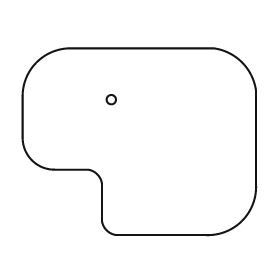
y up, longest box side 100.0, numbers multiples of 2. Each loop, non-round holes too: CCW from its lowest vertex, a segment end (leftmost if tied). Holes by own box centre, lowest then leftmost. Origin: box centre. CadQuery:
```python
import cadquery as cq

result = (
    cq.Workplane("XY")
    .moveTo(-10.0, -40.0)
    .lineTo(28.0, -40.0)
    .threePointArc((44.0, -34.0), (50.0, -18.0))
    .lineTo(50.0, 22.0)
    .threePointArc((44.0, 34.0), (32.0, 40.0))
    .lineTo(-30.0, 40.0)
    .threePointArc((-44.0, 34.0), (-50.0, 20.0))
    .lineTo(-50.0, 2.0)
    .threePointArc((-46.0, -8.0), (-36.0, -12.0))
    .lineTo(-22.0, -12.0)
    .threePointArc((-18.0, -14.0), (-16.0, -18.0))
    .lineTo(-16.0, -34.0)
    .threePointArc((-14.0, -38.0), (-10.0, -40.0))
    .close()
    .moveTo(-12.0, 18.0)
    .circle(2.0)
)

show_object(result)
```